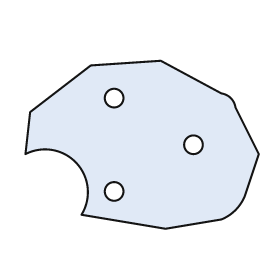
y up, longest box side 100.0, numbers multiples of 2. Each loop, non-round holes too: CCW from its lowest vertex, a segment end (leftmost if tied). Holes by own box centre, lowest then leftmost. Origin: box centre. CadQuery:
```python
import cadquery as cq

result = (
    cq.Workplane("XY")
    .moveTo(10.0, -36.0)
    .lineTo(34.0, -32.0)
    .threePointArc((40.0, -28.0), (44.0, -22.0))
    .lineTo(50.0, -4.0)
    .lineTo(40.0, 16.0)
    .threePointArc((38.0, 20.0), (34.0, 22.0))
    .lineTo(8.0, 36.0)
    .lineTo(-22.0, 34.0)
    .lineTo(-48.0, 14.0)
    .lineTo(-50.0, -4.0)
    .threePointArc((-28.0, -8.0), (-26.0, -30.0))
    .close()
    .moveTo(-12.0, -20.0)
    .circle(4.0)
    .moveTo(22.0, 0.0)
    .circle(4.0)
    .moveTo(-12.0, 20.0)
    .circle(4.0)
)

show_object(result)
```